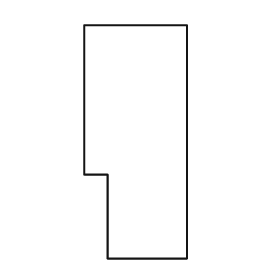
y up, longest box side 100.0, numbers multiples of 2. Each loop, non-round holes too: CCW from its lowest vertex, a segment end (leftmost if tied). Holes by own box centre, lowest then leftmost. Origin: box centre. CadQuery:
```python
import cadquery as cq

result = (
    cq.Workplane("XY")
    .moveTo(-12.0, -50.0)
    .lineTo(22.0, -50.0)
    .lineTo(22.0, 50.0)
    .lineTo(-22.0, 50.0)
    .lineTo(-22.0, -14.0)
    .lineTo(-12.0, -14.0)
    .close()
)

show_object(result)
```